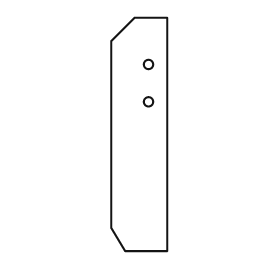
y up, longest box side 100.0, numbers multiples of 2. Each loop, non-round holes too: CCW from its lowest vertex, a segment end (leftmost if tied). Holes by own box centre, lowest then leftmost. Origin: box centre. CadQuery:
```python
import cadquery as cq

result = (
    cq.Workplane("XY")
    .moveTo(-6.0, -50.0)
    .lineTo(12.0, -50.0)
    .lineTo(12.0, 50.0)
    .lineTo(-2.0, 50.0)
    .lineTo(-12.0, 40.0)
    .lineTo(-12.0, -40.0)
    .close()
    .moveTo(4.0, 14.0)
    .circle(2.0)
    .moveTo(4.0, 30.0)
    .circle(2.0)
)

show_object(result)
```